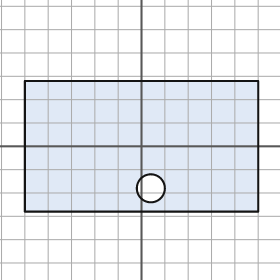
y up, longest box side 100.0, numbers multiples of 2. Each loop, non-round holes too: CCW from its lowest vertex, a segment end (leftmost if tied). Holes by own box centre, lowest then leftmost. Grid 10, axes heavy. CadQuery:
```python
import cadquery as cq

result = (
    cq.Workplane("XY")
    .moveTo(-50.0, -28.0)
    .lineTo(50.0, -28.0)
    .lineTo(50.0, 28.0)
    .lineTo(-50.0, 28.0)
    .close()
    .moveTo(4.0, -18.0)
    .circle(6.0)
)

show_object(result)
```